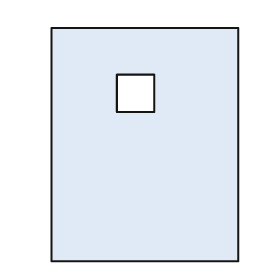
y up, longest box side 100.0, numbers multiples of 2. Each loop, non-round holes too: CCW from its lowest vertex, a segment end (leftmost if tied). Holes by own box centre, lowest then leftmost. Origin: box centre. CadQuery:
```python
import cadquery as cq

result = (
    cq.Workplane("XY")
    .moveTo(-40.0, -50.0)
    .lineTo(40.0, -50.0)
    .lineTo(40.0, 50.0)
    .lineTo(-40.0, 50.0)
    .close()
    .moveTo(-12.0, 14.0)
    .lineTo(4.0, 14.0)
    .lineTo(4.0, 30.0)
    .lineTo(-12.0, 30.0)
    .close()
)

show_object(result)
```